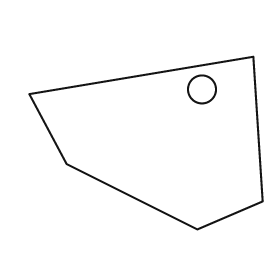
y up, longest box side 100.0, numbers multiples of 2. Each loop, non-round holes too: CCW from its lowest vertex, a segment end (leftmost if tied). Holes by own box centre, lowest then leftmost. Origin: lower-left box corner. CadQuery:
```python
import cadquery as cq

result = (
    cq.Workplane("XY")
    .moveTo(72.0, 0.0)
    .lineTo(100.0, 12.0)
    .lineTo(96.0, 74.0)
    .lineTo(0.0, 58.0)
    .lineTo(16.0, 28.0)
    .close()
    .moveTo(74.0, 60.0)
    .circle(6.0)
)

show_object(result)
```